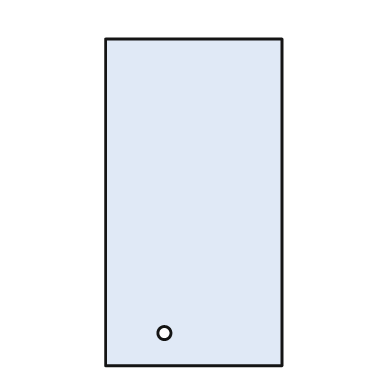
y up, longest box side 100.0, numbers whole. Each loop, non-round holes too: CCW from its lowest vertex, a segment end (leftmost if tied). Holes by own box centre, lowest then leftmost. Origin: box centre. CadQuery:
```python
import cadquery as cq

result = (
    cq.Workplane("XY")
    .moveTo(-27.0, -50.0)
    .lineTo(27.0, -50.0)
    .lineTo(27.0, 50.0)
    .lineTo(-27.0, 50.0)
    .close()
    .moveTo(-9.0, -40.0)
    .circle(2.0)
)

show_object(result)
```